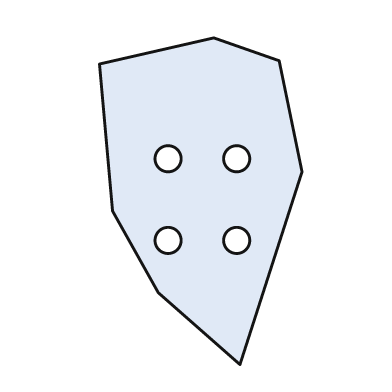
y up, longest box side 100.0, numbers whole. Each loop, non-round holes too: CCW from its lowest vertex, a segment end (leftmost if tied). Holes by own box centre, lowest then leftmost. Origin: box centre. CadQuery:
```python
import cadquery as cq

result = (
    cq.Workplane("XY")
    .moveTo(12.0, -50.0)
    .lineTo(31.0, 9.0)
    .lineTo(24.0, 43.0)
    .lineTo(4.0, 50.0)
    .lineTo(-31.0, 42.0)
    .lineTo(-27.0, -3.0)
    .lineTo(-13.0, -28.0)
    .close()
    .moveTo(-10.0, -12.0)
    .circle(4.0)
    .moveTo(11.0, -12.0)
    .circle(4.0)
    .moveTo(-10.0, 13.0)
    .circle(4.0)
    .moveTo(11.0, 13.0)
    .circle(4.0)
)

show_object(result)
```